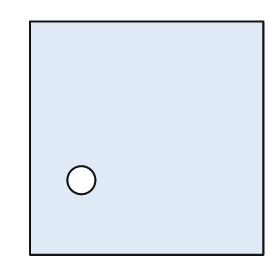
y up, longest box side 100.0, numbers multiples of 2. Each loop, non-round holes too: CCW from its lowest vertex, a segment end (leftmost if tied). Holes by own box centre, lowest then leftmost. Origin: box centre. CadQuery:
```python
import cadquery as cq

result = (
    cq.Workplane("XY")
    .moveTo(-50.0, -50.0)
    .lineTo(50.0, -50.0)
    .lineTo(50.0, 50.0)
    .lineTo(-50.0, 50.0)
    .close()
    .moveTo(-28.0, -18.0)
    .circle(6.0)
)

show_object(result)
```